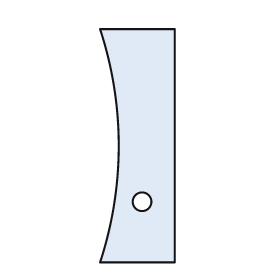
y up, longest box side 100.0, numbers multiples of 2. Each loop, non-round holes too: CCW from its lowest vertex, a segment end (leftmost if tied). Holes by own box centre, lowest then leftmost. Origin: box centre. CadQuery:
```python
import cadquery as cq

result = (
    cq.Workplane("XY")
    .moveTo(-16.0, -50.0)
    .lineTo(16.0, -50.0)
    .lineTo(16.0, 50.0)
    .lineTo(-16.0, 50.0)
    .threePointArc((-8.0, 0.0), (-16.0, -50.0))
    .close()
    .moveTo(2.0, -24.0)
    .circle(4.0)
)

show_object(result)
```